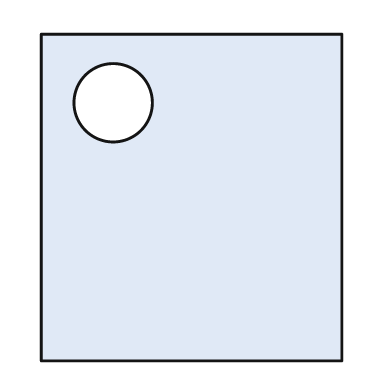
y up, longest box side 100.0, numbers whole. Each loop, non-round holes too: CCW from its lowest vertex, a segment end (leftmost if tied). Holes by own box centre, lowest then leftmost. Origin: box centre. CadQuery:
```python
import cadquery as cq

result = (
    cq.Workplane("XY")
    .moveTo(-46.0, -50.0)
    .lineTo(46.0, -50.0)
    .lineTo(46.0, 50.0)
    .lineTo(-46.0, 50.0)
    .close()
    .moveTo(-24.0, 29.0)
    .circle(12.0)
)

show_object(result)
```